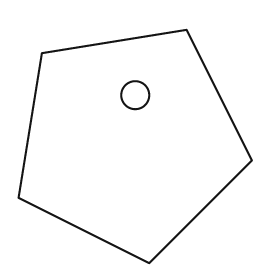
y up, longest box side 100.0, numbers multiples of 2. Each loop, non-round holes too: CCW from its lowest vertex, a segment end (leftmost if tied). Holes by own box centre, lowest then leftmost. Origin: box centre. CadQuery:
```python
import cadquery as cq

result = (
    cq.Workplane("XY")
    .moveTo(6.0, -50.0)
    .lineTo(50.0, -6.0)
    .lineTo(22.0, 50.0)
    .lineTo(-40.0, 40.0)
    .lineTo(-50.0, -22.0)
    .close()
    .moveTo(0.0, 22.0)
    .circle(6.0)
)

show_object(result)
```